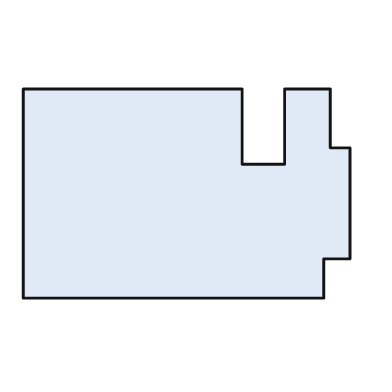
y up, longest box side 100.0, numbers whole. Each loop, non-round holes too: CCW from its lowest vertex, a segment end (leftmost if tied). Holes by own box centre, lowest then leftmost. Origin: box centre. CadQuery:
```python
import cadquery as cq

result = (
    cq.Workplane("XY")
    .moveTo(-50.0, -32.0)
    .lineTo(42.0, -32.0)
    .lineTo(42.0, -20.0)
    .lineTo(50.0, -20.0)
    .lineTo(50.0, 14.0)
    .lineTo(44.0, 14.0)
    .lineTo(44.0, 32.0)
    .lineTo(30.0, 32.0)
    .lineTo(30.0, 9.0)
    .lineTo(17.0, 9.0)
    .lineTo(17.0, 32.0)
    .lineTo(-50.0, 32.0)
    .close()
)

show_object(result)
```